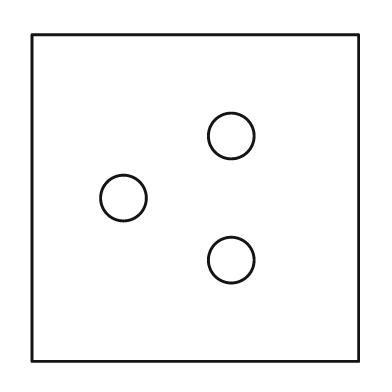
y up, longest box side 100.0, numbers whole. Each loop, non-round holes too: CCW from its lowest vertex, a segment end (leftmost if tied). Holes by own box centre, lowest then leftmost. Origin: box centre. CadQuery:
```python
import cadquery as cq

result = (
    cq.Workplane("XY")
    .moveTo(-50.0, -50.0)
    .lineTo(50.0, -50.0)
    .lineTo(50.0, 50.0)
    .lineTo(-50.0, 50.0)
    .close()
    .moveTo(11.0, -19.0)
    .circle(7.0)
    .moveTo(-22.0, 0.0)
    .circle(7.0)
    .moveTo(11.0, 19.0)
    .circle(7.0)
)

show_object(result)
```